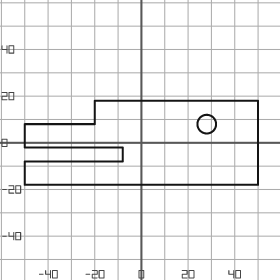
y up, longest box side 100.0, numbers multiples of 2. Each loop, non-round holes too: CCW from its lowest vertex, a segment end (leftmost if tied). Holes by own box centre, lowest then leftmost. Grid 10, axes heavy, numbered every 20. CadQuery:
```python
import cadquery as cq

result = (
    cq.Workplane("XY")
    .moveTo(-50.0, -18.0)
    .lineTo(50.0, -18.0)
    .lineTo(50.0, 18.0)
    .lineTo(-20.0, 18.0)
    .lineTo(-20.0, 8.0)
    .lineTo(-50.0, 8.0)
    .lineTo(-50.0, -2.0)
    .lineTo(-8.0, -2.0)
    .lineTo(-8.0, -8.0)
    .lineTo(-50.0, -8.0)
    .close()
    .moveTo(28.0, 8.0)
    .circle(4.0)
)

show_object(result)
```